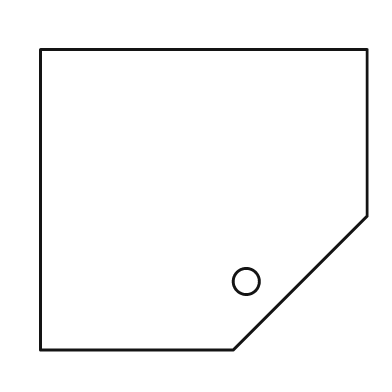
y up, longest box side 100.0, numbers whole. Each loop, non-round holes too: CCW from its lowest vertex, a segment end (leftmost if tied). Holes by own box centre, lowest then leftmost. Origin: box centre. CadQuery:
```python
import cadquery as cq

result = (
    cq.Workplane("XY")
    .moveTo(-50.0, -46.0)
    .lineTo(9.0, -46.0)
    .lineTo(50.0, -5.0)
    .lineTo(50.0, 46.0)
    .lineTo(-50.0, 46.0)
    .close()
    .moveTo(13.0, -25.0)
    .circle(4.0)
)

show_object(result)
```